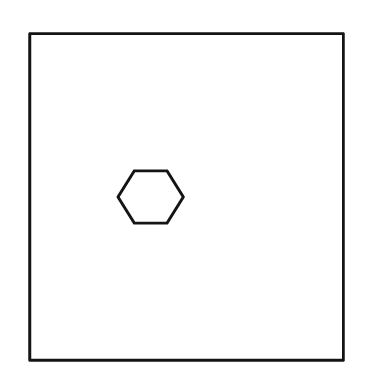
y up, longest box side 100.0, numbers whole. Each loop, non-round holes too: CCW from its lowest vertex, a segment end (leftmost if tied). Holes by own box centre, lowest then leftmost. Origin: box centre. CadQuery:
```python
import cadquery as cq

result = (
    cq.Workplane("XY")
    .moveTo(-48.0, -50.0)
    .lineTo(48.0, -50.0)
    .lineTo(48.0, 50.0)
    .lineTo(-48.0, 50.0)
    .close()
    .moveTo(-16.0, -8.0)
    .lineTo(-6.0, -8.0)
    .lineTo(-1.0, 0.0)
    .lineTo(-6.0, 8.0)
    .lineTo(-16.0, 8.0)
    .lineTo(-21.0, 0.0)
    .close()
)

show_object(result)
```